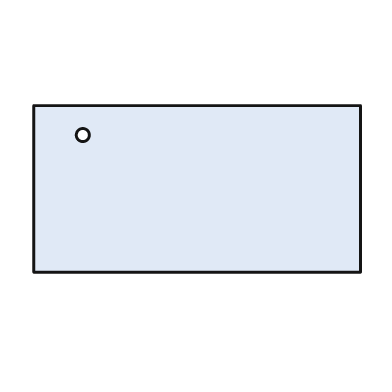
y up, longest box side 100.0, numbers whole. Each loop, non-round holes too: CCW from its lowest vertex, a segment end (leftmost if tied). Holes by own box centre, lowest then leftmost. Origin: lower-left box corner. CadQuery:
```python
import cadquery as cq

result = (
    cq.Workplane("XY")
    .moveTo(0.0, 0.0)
    .lineTo(100.0, 0.0)
    .lineTo(100.0, 51.0)
    .lineTo(0.0, 51.0)
    .close()
    .moveTo(15.0, 42.0)
    .circle(2.0)
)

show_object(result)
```